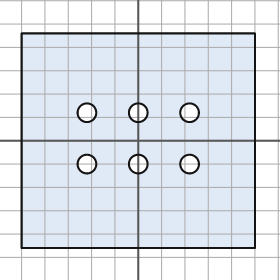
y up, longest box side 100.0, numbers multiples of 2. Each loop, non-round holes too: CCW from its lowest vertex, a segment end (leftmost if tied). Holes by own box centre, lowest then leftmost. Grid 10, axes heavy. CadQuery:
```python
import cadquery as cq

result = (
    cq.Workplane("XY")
    .moveTo(-50.0, -46.0)
    .lineTo(50.0, -46.0)
    .lineTo(50.0, 46.0)
    .lineTo(-50.0, 46.0)
    .close()
    .moveTo(-22.0, -10.0)
    .circle(4.0)
    .moveTo(0.0, -10.0)
    .circle(4.0)
    .moveTo(22.0, -10.0)
    .circle(4.0)
    .moveTo(-22.0, 12.0)
    .circle(4.0)
    .moveTo(0.0, 12.0)
    .circle(4.0)
    .moveTo(22.0, 12.0)
    .circle(4.0)
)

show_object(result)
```